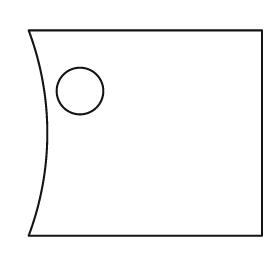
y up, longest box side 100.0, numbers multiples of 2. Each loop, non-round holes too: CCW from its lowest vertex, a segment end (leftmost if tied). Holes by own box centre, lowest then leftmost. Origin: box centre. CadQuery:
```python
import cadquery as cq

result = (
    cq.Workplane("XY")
    .moveTo(-50.0, -44.0)
    .lineTo(50.0, -44.0)
    .lineTo(50.0, 44.0)
    .lineTo(-50.0, 44.0)
    .threePointArc((-42.0, 0.0), (-50.0, -44.0))
    .close()
    .moveTo(-28.0, 18.0)
    .circle(10.0)
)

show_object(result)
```